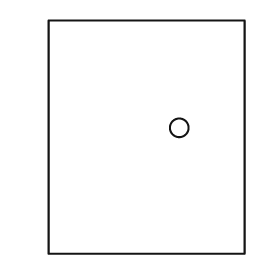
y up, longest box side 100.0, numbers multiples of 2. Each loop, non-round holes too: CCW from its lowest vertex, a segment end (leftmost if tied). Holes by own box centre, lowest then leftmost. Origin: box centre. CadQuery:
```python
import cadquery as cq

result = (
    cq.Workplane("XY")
    .moveTo(-42.0, -50.0)
    .lineTo(42.0, -50.0)
    .lineTo(42.0, 50.0)
    .lineTo(-42.0, 50.0)
    .close()
    .moveTo(14.0, 4.0)
    .circle(4.0)
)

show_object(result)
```